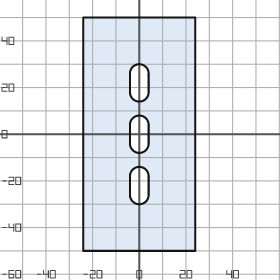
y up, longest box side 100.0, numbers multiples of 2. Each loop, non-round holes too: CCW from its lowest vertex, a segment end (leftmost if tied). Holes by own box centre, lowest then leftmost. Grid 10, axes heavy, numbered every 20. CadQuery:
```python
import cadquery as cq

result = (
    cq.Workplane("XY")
    .moveTo(-24.0, -50.0)
    .lineTo(24.0, -50.0)
    .lineTo(24.0, 50.0)
    .lineTo(-24.0, 50.0)
    .close()
    .moveTo(-4.0, -26.0)
    .threePointArc((0.0, -30.0), (4.0, -26.0))
    .lineTo(4.0, -18.0)
    .threePointArc((0.0, -14.0), (-4.0, -18.0))
    .close()
    .moveTo(-4.0, -4.0)
    .threePointArc((0.0, -8.0), (4.0, -4.0))
    .lineTo(4.0, 4.0)
    .threePointArc((0.0, 8.0), (-4.0, 4.0))
    .close()
    .moveTo(-4.0, 18.0)
    .threePointArc((0.0, 14.0), (4.0, 18.0))
    .lineTo(4.0, 26.0)
    .threePointArc((0.0, 30.0), (-4.0, 26.0))
    .close()
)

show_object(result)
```